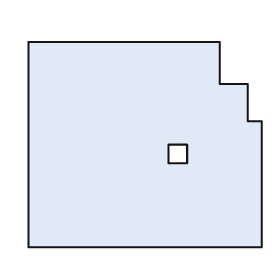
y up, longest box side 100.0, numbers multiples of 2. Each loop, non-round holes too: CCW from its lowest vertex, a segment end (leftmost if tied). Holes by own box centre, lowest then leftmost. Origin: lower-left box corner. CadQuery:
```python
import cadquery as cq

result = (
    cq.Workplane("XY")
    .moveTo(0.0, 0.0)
    .lineTo(100.0, 0.0)
    .lineTo(100.0, 54.0)
    .lineTo(94.0, 54.0)
    .lineTo(94.0, 70.0)
    .lineTo(82.0, 70.0)
    .lineTo(82.0, 88.0)
    .lineTo(0.0, 88.0)
    .close()
    .moveTo(60.0, 36.0)
    .lineTo(68.0, 36.0)
    .lineTo(68.0, 44.0)
    .lineTo(60.0, 44.0)
    .close()
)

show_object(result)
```